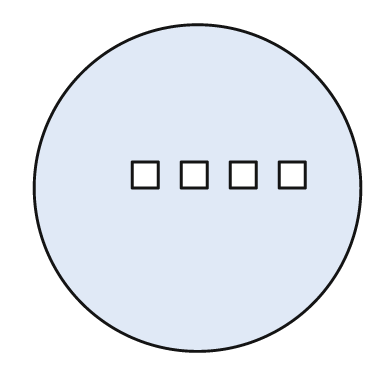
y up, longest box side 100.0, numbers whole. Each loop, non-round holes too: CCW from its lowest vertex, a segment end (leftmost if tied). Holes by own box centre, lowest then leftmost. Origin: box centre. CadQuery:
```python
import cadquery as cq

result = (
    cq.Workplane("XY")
    .moveTo(0.0, 0.0)
    .circle(50.0)
    .moveTo(-20.0, 0.0)
    .lineTo(-12.0, 0.0)
    .lineTo(-12.0, 8.0)
    .lineTo(-20.0, 8.0)
    .close()
    .moveTo(-5.0, 0.0)
    .lineTo(3.0, 0.0)
    .lineTo(3.0, 8.0)
    .lineTo(-5.0, 8.0)
    .close()
    .moveTo(10.0, 0.0)
    .lineTo(18.0, 0.0)
    .lineTo(18.0, 8.0)
    .lineTo(10.0, 8.0)
    .close()
    .moveTo(25.0, 0.0)
    .lineTo(33.0, 0.0)
    .lineTo(33.0, 8.0)
    .lineTo(25.0, 8.0)
    .close()
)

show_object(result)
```